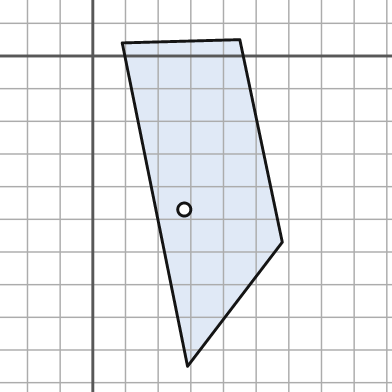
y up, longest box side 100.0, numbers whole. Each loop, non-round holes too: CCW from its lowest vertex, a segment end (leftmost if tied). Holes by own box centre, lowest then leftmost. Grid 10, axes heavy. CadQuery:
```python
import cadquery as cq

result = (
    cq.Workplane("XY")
    .moveTo(29.0, -95.0)
    .lineTo(58.0, -57.0)
    .lineTo(45.0, 5.0)
    .lineTo(9.0, 4.0)
    .close()
    .moveTo(28.0, -47.0)
    .circle(2.0)
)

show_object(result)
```